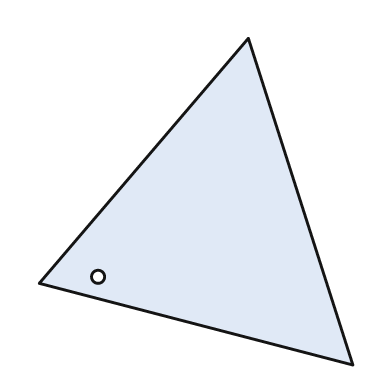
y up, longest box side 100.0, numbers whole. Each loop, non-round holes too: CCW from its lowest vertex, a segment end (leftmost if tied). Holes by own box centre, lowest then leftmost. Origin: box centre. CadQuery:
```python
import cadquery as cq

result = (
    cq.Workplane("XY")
    .moveTo(48.0, -50.0)
    .lineTo(16.0, 50.0)
    .lineTo(-48.0, -25.0)
    .close()
    .moveTo(-30.0, -23.0)
    .circle(2.0)
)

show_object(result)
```